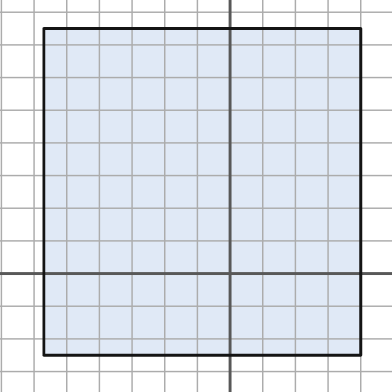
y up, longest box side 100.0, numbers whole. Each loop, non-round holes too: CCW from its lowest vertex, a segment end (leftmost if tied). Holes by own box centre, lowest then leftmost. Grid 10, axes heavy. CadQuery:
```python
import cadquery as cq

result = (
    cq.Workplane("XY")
    .moveTo(-57.0, -25.0)
    .lineTo(40.0, -25.0)
    .lineTo(40.0, 75.0)
    .lineTo(-57.0, 75.0)
    .close()
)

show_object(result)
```